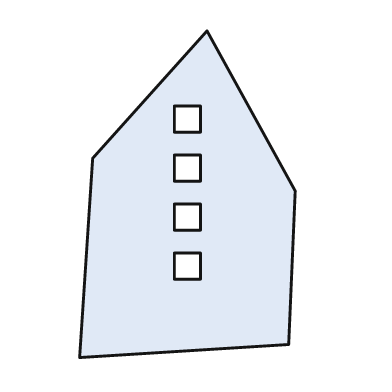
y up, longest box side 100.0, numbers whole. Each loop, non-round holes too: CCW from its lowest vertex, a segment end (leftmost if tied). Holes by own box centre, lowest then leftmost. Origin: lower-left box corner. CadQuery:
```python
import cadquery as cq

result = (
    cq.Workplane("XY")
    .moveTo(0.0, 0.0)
    .lineTo(64.0, 4.0)
    .lineTo(66.0, 51.0)
    .lineTo(39.0, 100.0)
    .lineTo(4.0, 61.0)
    .close()
    .moveTo(29.0, 24.0)
    .lineTo(37.0, 24.0)
    .lineTo(37.0, 32.0)
    .lineTo(29.0, 32.0)
    .close()
    .moveTo(29.0, 39.0)
    .lineTo(37.0, 39.0)
    .lineTo(37.0, 47.0)
    .lineTo(29.0, 47.0)
    .close()
    .moveTo(29.0, 54.0)
    .lineTo(37.0, 54.0)
    .lineTo(37.0, 62.0)
    .lineTo(29.0, 62.0)
    .close()
    .moveTo(29.0, 69.0)
    .lineTo(37.0, 69.0)
    .lineTo(37.0, 77.0)
    .lineTo(29.0, 77.0)
    .close()
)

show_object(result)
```